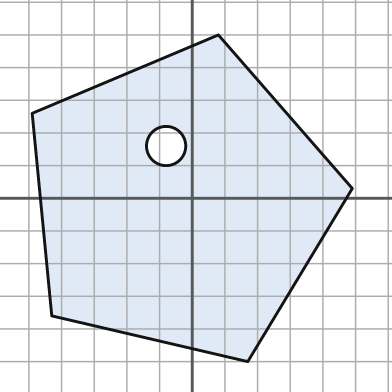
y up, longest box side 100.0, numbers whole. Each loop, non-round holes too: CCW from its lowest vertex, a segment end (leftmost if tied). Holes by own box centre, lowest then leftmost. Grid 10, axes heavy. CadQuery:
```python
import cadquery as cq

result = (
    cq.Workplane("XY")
    .moveTo(17.0, -50.0)
    .lineTo(49.0, 3.0)
    .lineTo(8.0, 50.0)
    .lineTo(-49.0, 26.0)
    .lineTo(-43.0, -36.0)
    .close()
    .moveTo(-8.0, 16.0)
    .circle(6.0)
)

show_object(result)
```